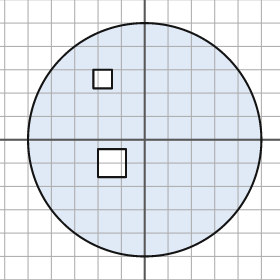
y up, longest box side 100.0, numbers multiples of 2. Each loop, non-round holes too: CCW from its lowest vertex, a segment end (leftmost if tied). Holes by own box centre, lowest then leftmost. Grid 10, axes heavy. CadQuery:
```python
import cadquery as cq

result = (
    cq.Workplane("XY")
    .moveTo(0.0, 0.0)
    .circle(50.0)
    .moveTo(-20.0, -16.0)
    .lineTo(-8.0, -16.0)
    .lineTo(-8.0, -4.0)
    .lineTo(-20.0, -4.0)
    .close()
    .moveTo(-22.0, 22.0)
    .lineTo(-14.0, 22.0)
    .lineTo(-14.0, 30.0)
    .lineTo(-22.0, 30.0)
    .close()
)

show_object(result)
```